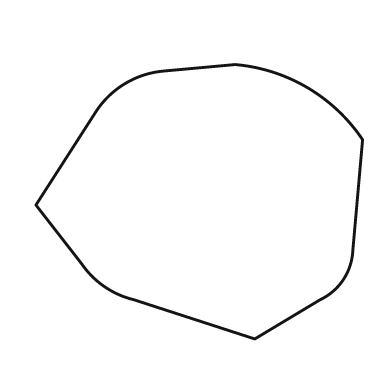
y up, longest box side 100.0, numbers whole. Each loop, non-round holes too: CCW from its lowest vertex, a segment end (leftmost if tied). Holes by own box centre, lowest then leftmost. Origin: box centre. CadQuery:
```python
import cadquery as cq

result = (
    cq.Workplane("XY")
    .moveTo(17.0, -42.0)
    .lineTo(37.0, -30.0)
    .threePointArc((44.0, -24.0), (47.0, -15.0))
    .lineTo(50.0, 19.0)
    .threePointArc((33.0, 35.0), (11.0, 42.0))
    .lineTo(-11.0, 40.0)
    .threePointArc((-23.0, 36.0), (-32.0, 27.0))
    .lineTo(-50.0, -1.0)
    .lineTo(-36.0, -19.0)
    .threePointArc((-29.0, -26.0), (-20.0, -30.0))
    .close()
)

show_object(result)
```